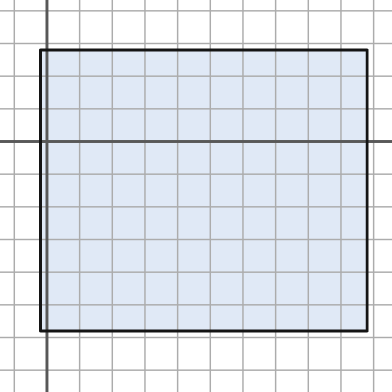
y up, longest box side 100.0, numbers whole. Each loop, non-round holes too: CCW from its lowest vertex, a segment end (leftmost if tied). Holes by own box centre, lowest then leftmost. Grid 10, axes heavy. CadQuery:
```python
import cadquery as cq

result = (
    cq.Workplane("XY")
    .moveTo(-2.0, -58.0)
    .lineTo(98.0, -58.0)
    .lineTo(98.0, 28.0)
    .lineTo(-2.0, 28.0)
    .close()
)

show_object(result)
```